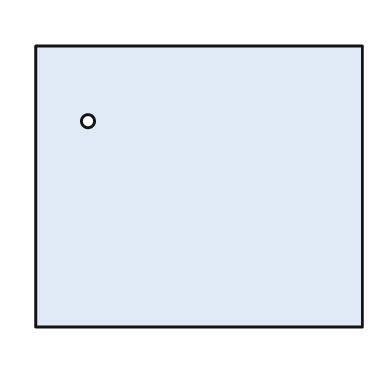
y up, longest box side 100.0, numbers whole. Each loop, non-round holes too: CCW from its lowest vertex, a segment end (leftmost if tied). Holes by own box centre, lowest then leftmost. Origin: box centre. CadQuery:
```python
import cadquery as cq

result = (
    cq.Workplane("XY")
    .moveTo(-50.0, -43.0)
    .lineTo(50.0, -43.0)
    .lineTo(50.0, 43.0)
    .lineTo(-50.0, 43.0)
    .close()
    .moveTo(-34.0, 20.0)
    .circle(2.0)
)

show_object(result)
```